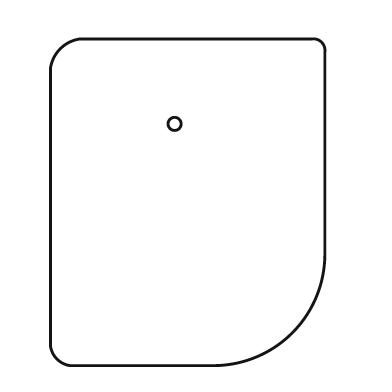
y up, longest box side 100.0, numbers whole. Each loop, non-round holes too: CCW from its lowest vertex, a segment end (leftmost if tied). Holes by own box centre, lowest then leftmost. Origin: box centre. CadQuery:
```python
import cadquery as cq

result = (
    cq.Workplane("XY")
    .moveTo(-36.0, -50.0)
    .lineTo(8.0, -50.0)
    .threePointArc((32.0, -40.0), (42.0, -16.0))
    .lineTo(42.0, 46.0)
    .threePointArc((41.0, 49.0), (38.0, 50.0))
    .lineTo(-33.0, 50.0)
    .threePointArc((-39.0, 47.0), (-42.0, 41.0))
    .lineTo(-42.0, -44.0)
    .threePointArc((-40.0, -48.0), (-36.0, -50.0))
    .close()
    .moveTo(-4.0, 24.0)
    .circle(2.0)
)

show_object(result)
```